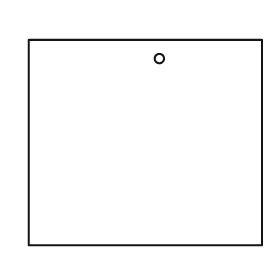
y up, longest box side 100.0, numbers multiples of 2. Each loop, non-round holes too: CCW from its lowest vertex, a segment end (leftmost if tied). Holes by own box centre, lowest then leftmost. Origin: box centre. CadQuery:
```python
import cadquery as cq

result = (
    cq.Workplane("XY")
    .moveTo(-50.0, -44.0)
    .lineTo(50.0, -44.0)
    .lineTo(50.0, 44.0)
    .lineTo(-50.0, 44.0)
    .close()
    .moveTo(6.0, 36.0)
    .circle(2.0)
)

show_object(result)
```